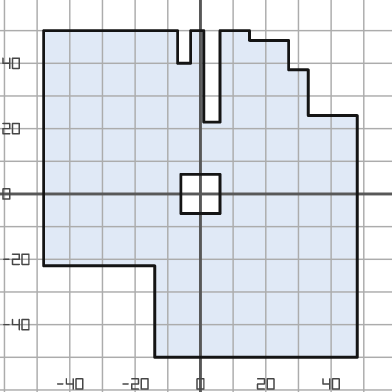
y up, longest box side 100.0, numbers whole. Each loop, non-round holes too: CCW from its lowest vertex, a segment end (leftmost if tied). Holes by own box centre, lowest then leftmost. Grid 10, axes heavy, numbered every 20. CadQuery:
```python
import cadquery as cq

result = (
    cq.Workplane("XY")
    .moveTo(-14.0, -50.0)
    .lineTo(48.0, -50.0)
    .lineTo(48.0, 24.0)
    .lineTo(33.0, 24.0)
    .lineTo(33.0, 38.0)
    .lineTo(27.0, 38.0)
    .lineTo(27.0, 47.0)
    .lineTo(15.0, 47.0)
    .lineTo(15.0, 50.0)
    .lineTo(6.0, 50.0)
    .lineTo(6.0, 22.0)
    .lineTo(1.0, 22.0)
    .lineTo(1.0, 50.0)
    .lineTo(-3.0, 50.0)
    .lineTo(-3.0, 40.0)
    .lineTo(-7.0, 40.0)
    .lineTo(-7.0, 50.0)
    .lineTo(-48.0, 50.0)
    .lineTo(-48.0, -22.0)
    .lineTo(-14.0, -22.0)
    .close()
    .moveTo(-6.0, -6.0)
    .lineTo(6.0, -6.0)
    .lineTo(6.0, 6.0)
    .lineTo(-6.0, 6.0)
    .close()
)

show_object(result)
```